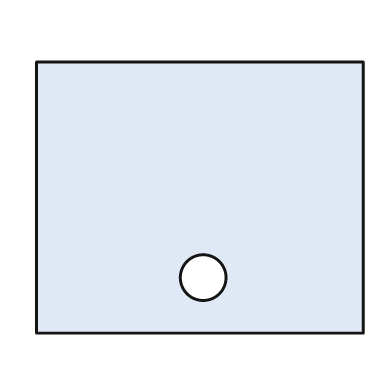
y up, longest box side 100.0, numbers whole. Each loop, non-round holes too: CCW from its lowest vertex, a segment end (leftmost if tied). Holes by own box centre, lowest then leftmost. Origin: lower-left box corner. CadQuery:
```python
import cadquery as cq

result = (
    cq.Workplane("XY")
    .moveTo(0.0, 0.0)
    .lineTo(100.0, 0.0)
    .lineTo(100.0, 83.0)
    .lineTo(0.0, 83.0)
    .close()
    .moveTo(51.0, 17.0)
    .circle(7.0)
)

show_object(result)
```